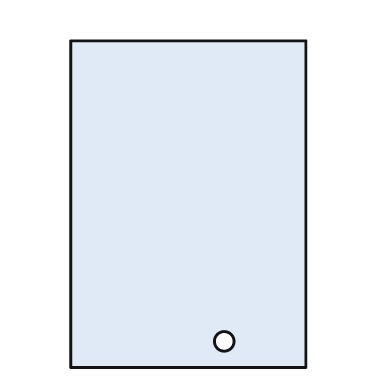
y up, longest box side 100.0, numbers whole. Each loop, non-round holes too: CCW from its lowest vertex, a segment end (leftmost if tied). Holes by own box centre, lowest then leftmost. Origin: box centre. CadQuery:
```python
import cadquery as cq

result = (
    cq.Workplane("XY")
    .moveTo(-36.0, -50.0)
    .lineTo(36.0, -50.0)
    .lineTo(36.0, 50.0)
    .lineTo(-36.0, 50.0)
    .close()
    .moveTo(11.0, -42.0)
    .circle(3.0)
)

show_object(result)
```